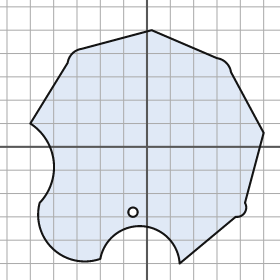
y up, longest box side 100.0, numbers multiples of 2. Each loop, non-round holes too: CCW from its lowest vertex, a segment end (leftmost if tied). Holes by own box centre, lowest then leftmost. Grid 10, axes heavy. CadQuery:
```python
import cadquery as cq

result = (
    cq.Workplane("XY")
    .moveTo(14.0, -50.0)
    .lineTo(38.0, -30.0)
    .threePointArc((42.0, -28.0), (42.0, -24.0))
    .lineTo(50.0, 6.0)
    .lineTo(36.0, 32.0)
    .threePointArc((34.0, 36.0), (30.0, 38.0))
    .lineTo(2.0, 50.0)
    .lineTo(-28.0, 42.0)
    .threePointArc((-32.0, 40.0), (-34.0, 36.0))
    .lineTo(-50.0, 10.0)
    .threePointArc((-40.0, -6.0), (-46.0, -24.0))
    .threePointArc((-40.0, -44.0), (-20.0, -48.0))
    .threePointArc((-2.0, -34.0), (14.0, -50.0))
    .close()
    .moveTo(-6.0, -28.0)
    .circle(2.0)
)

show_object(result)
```